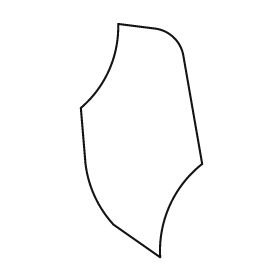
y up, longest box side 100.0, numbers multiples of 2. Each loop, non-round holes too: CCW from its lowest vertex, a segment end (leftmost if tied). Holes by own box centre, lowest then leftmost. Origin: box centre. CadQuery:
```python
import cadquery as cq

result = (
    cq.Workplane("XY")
    .moveTo(8.0, -50.0)
    .threePointArc((12.0, -28.0), (26.0, -10.0))
    .lineTo(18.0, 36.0)
    .threePointArc((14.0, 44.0), (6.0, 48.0))
    .lineTo(-10.0, 50.0)
    .threePointArc((-14.0, 30.0), (-26.0, 14.0))
    .lineTo(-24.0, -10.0)
    .threePointArc((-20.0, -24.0), (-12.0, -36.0))
    .close()
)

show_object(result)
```